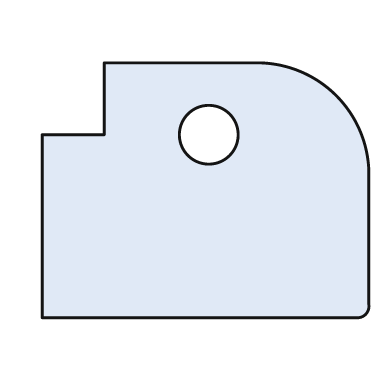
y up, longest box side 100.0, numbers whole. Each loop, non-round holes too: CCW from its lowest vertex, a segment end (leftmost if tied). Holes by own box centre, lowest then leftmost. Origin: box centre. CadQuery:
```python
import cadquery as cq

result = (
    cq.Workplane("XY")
    .moveTo(-50.0, -39.0)
    .lineTo(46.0, -39.0)
    .threePointArc((49.0, -38.0), (50.0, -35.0))
    .lineTo(50.0, 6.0)
    .threePointArc((40.0, 29.0), (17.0, 39.0))
    .lineTo(-31.0, 39.0)
    .lineTo(-31.0, 17.0)
    .lineTo(-50.0, 17.0)
    .close()
    .moveTo(1.0, 17.0)
    .circle(9.0)
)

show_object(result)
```